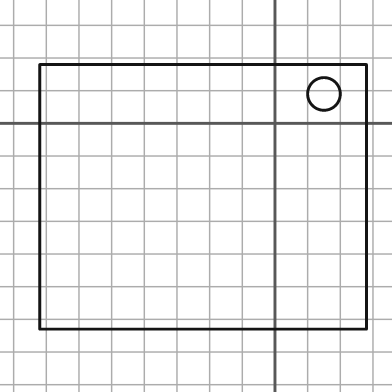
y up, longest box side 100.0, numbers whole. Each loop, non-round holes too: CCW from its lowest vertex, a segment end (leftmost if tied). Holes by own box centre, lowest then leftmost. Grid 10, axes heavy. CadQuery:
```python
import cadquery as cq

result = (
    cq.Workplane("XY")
    .moveTo(-72.0, -63.0)
    .lineTo(28.0, -63.0)
    .lineTo(28.0, 18.0)
    .lineTo(-72.0, 18.0)
    .close()
    .moveTo(15.0, 9.0)
    .circle(5.0)
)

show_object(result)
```